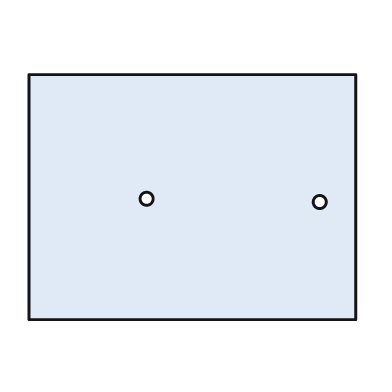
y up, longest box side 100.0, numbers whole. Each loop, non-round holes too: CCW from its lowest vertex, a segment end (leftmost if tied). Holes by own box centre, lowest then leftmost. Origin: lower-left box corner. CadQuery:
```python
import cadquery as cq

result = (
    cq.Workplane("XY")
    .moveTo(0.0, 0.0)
    .lineTo(100.0, 0.0)
    .lineTo(100.0, 75.0)
    .lineTo(0.0, 75.0)
    .close()
    .moveTo(89.0, 36.0)
    .circle(2.0)
    .moveTo(36.0, 37.0)
    .circle(2.0)
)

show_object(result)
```